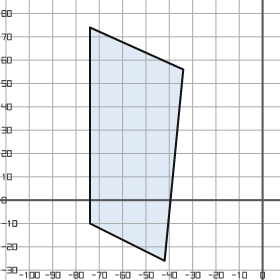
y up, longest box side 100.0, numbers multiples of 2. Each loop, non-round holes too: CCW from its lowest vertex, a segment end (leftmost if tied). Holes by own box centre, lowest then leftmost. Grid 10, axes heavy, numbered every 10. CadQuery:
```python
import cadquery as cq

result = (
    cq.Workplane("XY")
    .moveTo(-42.0, -26.0)
    .lineTo(-34.0, 56.0)
    .lineTo(-74.0, 74.0)
    .lineTo(-74.0, -10.0)
    .close()
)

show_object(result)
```